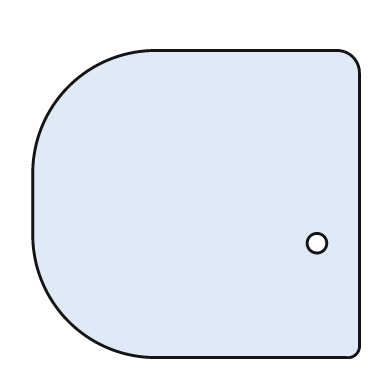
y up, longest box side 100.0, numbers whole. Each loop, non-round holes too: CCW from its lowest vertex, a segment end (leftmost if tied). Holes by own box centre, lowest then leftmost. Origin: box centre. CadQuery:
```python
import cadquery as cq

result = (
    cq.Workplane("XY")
    .moveTo(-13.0, -47.0)
    .lineTo(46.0, -47.0)
    .threePointArc((49.0, -46.0), (50.0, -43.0))
    .lineTo(50.0, 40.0)
    .threePointArc((48.0, 45.0), (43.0, 47.0))
    .lineTo(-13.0, 47.0)
    .threePointArc((-39.0, 36.0), (-50.0, 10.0))
    .lineTo(-50.0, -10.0)
    .threePointArc((-39.0, -36.0), (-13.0, -47.0))
    .close()
    .moveTo(37.0, -12.0)
    .circle(3.0)
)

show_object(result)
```